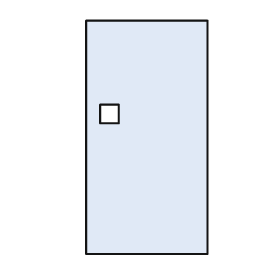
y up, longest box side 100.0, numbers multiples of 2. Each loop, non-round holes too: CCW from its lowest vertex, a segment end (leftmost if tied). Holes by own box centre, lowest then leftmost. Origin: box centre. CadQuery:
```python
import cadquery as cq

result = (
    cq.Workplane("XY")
    .moveTo(-26.0, -50.0)
    .lineTo(26.0, -50.0)
    .lineTo(26.0, 50.0)
    .lineTo(-26.0, 50.0)
    .close()
    .moveTo(-20.0, 6.0)
    .lineTo(-12.0, 6.0)
    .lineTo(-12.0, 14.0)
    .lineTo(-20.0, 14.0)
    .close()
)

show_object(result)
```